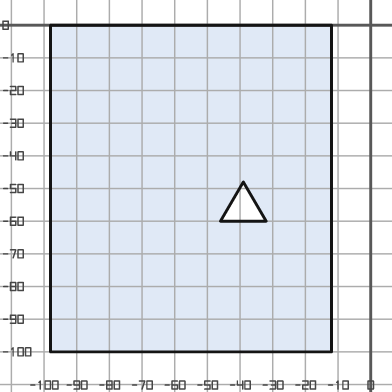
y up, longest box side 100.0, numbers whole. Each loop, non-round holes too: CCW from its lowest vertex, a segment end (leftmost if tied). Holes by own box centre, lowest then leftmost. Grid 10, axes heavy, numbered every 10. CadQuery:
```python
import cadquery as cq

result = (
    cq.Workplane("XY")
    .moveTo(-98.0, -100.0)
    .lineTo(-12.0, -100.0)
    .lineTo(-12.0, 0.0)
    .lineTo(-98.0, 0.0)
    .close()
    .moveTo(-46.0, -60.0)
    .lineTo(-32.0, -60.0)
    .lineTo(-39.0, -48.0)
    .close()
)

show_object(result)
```